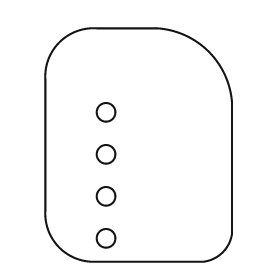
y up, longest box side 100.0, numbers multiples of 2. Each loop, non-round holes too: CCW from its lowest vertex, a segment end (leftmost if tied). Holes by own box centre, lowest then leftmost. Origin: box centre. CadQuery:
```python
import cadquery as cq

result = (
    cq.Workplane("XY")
    .moveTo(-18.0, -50.0)
    .lineTo(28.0, -50.0)
    .threePointArc((36.0, -46.0), (40.0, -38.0))
    .lineTo(40.0, 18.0)
    .threePointArc((30.0, 40.0), (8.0, 50.0))
    .lineTo(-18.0, 50.0)
    .threePointArc((-34.0, 44.0), (-40.0, 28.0))
    .lineTo(-40.0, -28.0)
    .threePointArc((-34.0, -44.0), (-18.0, -50.0))
    .close()
    .moveTo(-14.0, -40.0)
    .circle(4.0)
    .moveTo(-14.0, -22.0)
    .circle(4.0)
    .moveTo(-14.0, -4.0)
    .circle(4.0)
    .moveTo(-14.0, 14.0)
    .circle(4.0)
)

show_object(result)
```